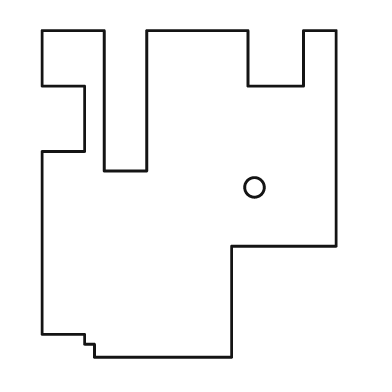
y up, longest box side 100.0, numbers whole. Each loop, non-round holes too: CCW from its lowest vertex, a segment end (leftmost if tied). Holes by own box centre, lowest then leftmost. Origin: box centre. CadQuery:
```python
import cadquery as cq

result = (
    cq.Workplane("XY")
    .moveTo(-29.0, -50.0)
    .lineTo(13.0, -50.0)
    .lineTo(13.0, -16.0)
    .lineTo(45.0, -16.0)
    .lineTo(45.0, 50.0)
    .lineTo(35.0, 50.0)
    .lineTo(35.0, 33.0)
    .lineTo(18.0, 33.0)
    .lineTo(18.0, 50.0)
    .lineTo(-13.0, 50.0)
    .lineTo(-13.0, 7.0)
    .lineTo(-26.0, 7.0)
    .lineTo(-26.0, 50.0)
    .lineTo(-45.0, 50.0)
    .lineTo(-45.0, 33.0)
    .lineTo(-32.0, 33.0)
    .lineTo(-32.0, 13.0)
    .lineTo(-45.0, 13.0)
    .lineTo(-45.0, -43.0)
    .lineTo(-32.0, -43.0)
    .lineTo(-32.0, -46.0)
    .lineTo(-29.0, -46.0)
    .close()
    .moveTo(20.0, 2.0)
    .circle(3.0)
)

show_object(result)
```